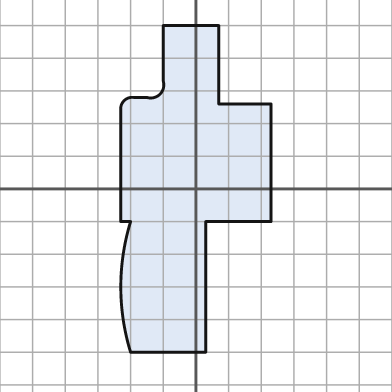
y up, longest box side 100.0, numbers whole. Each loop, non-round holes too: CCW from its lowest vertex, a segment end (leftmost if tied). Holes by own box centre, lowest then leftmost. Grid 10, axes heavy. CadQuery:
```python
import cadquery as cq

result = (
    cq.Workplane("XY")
    .moveTo(-20.0, -50.0)
    .lineTo(3.0, -50.0)
    .lineTo(3.0, -10.0)
    .lineTo(23.0, -10.0)
    .lineTo(23.0, 26.0)
    .lineTo(7.0, 26.0)
    .lineTo(7.0, 50.0)
    .lineTo(-10.0, 50.0)
    .lineTo(-10.0, 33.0)
    .threePointArc((-11.0, 29.0), (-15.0, 28.0))
    .lineTo(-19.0, 28.0)
    .threePointArc((-22.0, 27.0), (-23.0, 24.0))
    .lineTo(-23.0, -10.0)
    .lineTo(-20.0, -10.0)
    .threePointArc((-23.0, -30.0), (-20.0, -50.0))
    .close()
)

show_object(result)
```